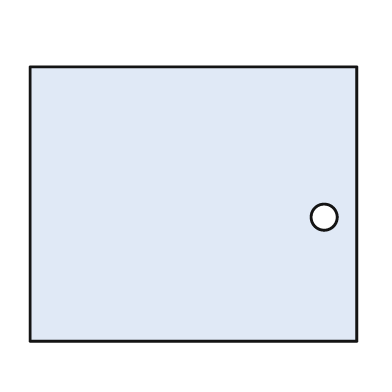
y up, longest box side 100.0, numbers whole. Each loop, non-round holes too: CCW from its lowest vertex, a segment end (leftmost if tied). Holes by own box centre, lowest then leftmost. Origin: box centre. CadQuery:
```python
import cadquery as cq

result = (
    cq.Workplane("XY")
    .moveTo(-50.0, -42.0)
    .lineTo(50.0, -42.0)
    .lineTo(50.0, 42.0)
    .lineTo(-50.0, 42.0)
    .close()
    .moveTo(40.0, -4.0)
    .circle(4.0)
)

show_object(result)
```